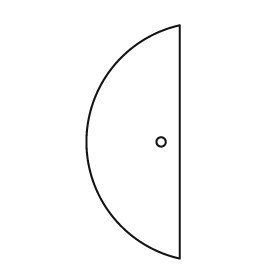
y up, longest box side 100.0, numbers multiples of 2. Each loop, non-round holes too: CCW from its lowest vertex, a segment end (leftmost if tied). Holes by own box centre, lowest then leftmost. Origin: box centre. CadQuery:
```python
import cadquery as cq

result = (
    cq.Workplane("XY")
    .moveTo(20.0, -50.0)
    .lineTo(20.0, 50.0)
    .threePointArc((-20.0, 0.0), (20.0, -50.0))
    .close()
    .moveTo(12.0, 0.0)
    .circle(2.0)
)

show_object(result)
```